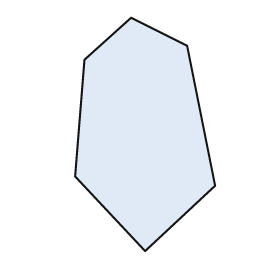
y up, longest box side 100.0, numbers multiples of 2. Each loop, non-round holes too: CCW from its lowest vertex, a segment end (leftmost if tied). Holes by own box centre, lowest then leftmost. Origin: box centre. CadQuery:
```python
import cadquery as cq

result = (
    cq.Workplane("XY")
    .moveTo(0.0, -50.0)
    .lineTo(30.0, -22.0)
    .lineTo(18.0, 38.0)
    .lineTo(-6.0, 50.0)
    .lineTo(-26.0, 32.0)
    .lineTo(-30.0, -18.0)
    .close()
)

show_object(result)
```